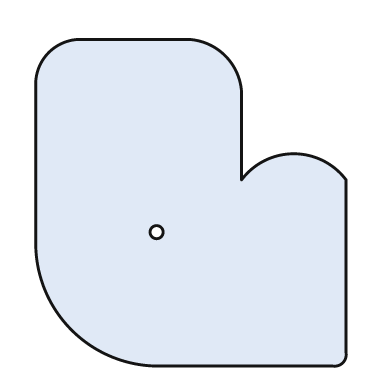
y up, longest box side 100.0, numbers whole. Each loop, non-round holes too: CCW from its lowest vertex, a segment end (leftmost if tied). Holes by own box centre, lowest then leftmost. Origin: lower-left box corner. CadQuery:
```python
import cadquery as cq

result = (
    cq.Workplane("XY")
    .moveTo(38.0, 0.0)
    .lineTo(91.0, 0.0)
    .threePointArc((94.0, 1.0), (95.0, 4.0))
    .lineTo(95.0, 57.0)
    .threePointArc((79.0, 65.0), (63.0, 57.0))
    .lineTo(63.0, 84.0)
    .threePointArc((58.0, 95.0), (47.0, 100.0))
    .lineTo(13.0, 100.0)
    .threePointArc((4.0, 96.0), (0.0, 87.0))
    .lineTo(0.0, 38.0)
    .threePointArc((11.0, 11.0), (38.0, 0.0))
    .close()
    .moveTo(37.0, 41.0)
    .circle(2.0)
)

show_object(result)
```